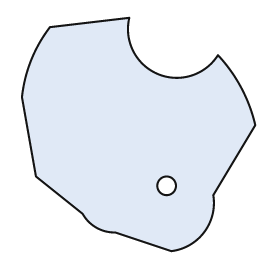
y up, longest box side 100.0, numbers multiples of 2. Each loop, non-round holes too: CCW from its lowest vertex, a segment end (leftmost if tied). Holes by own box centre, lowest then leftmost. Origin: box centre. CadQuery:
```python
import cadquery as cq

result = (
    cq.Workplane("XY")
    .moveTo(14.0, -50.0)
    .threePointArc((28.0, -42.0), (32.0, -26.0))
    .lineTo(50.0, 4.0)
    .threePointArc((44.0, 20.0), (34.0, 34.0))
    .threePointArc((8.0, 26.0), (-4.0, 50.0))
    .lineTo(-38.0, 46.0)
    .threePointArc((-46.0, 32.0), (-50.0, 16.0))
    .lineTo(-44.0, -18.0)
    .lineTo(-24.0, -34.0)
    .threePointArc((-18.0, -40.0), (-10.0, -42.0))
    .close()
    .moveTo(12.0, -22.0)
    .circle(4.0)
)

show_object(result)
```